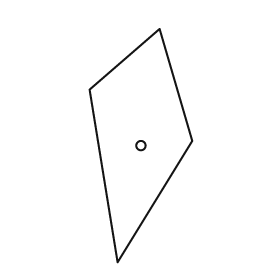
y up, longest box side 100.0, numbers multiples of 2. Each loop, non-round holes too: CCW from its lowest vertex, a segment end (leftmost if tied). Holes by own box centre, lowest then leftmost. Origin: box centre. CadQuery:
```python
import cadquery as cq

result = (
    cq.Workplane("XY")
    .moveTo(-10.0, -50.0)
    .lineTo(22.0, 2.0)
    .lineTo(8.0, 50.0)
    .lineTo(-22.0, 24.0)
    .close()
    .moveTo(0.0, 0.0)
    .circle(2.0)
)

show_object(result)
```